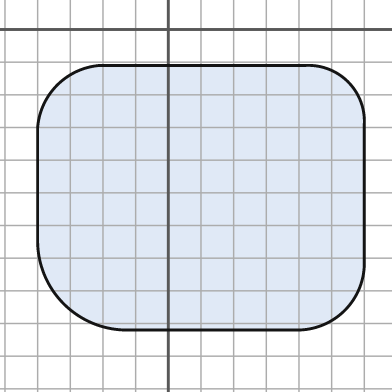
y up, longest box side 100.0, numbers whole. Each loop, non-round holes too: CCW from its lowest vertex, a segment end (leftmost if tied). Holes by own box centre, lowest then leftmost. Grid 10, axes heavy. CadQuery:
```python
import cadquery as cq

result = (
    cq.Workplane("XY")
    .moveTo(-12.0, -92.0)
    .lineTo(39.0, -92.0)
    .threePointArc((54.0, -86.0), (60.0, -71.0))
    .lineTo(60.0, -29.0)
    .threePointArc((55.0, -16.0), (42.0, -11.0))
    .lineTo(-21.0, -11.0)
    .threePointArc((-34.0, -17.0), (-40.0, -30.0))
    .lineTo(-40.0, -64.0)
    .threePointArc((-32.0, -84.0), (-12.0, -92.0))
    .close()
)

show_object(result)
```